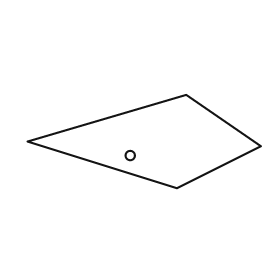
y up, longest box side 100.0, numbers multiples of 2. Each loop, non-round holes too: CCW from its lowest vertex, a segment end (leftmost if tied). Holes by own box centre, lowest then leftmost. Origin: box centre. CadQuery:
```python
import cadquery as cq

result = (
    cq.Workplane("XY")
    .moveTo(14.0, -20.0)
    .lineTo(50.0, -2.0)
    .lineTo(18.0, 20.0)
    .lineTo(-50.0, 0.0)
    .close()
    .moveTo(-6.0, -6.0)
    .circle(2.0)
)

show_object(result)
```